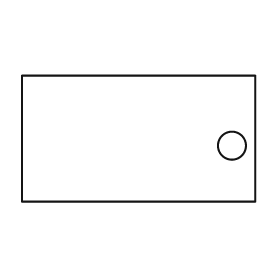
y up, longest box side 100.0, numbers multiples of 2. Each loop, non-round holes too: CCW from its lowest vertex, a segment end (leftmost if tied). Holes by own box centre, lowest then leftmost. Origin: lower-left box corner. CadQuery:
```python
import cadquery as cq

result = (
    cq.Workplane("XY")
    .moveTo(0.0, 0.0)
    .lineTo(100.0, 0.0)
    .lineTo(100.0, 54.0)
    .lineTo(0.0, 54.0)
    .close()
    .moveTo(90.0, 24.0)
    .circle(6.0)
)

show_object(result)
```